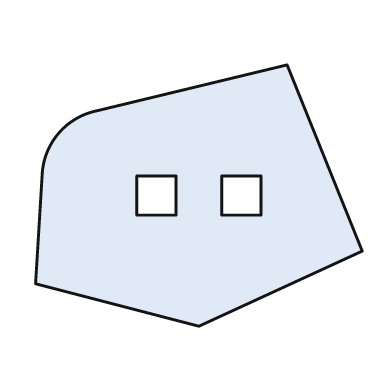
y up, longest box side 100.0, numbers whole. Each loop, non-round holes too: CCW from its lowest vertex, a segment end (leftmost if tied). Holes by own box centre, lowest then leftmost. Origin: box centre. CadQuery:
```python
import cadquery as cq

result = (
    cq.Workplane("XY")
    .moveTo(0.0, -40.0)
    .lineTo(50.0, -17.0)
    .lineTo(27.0, 40.0)
    .lineTo(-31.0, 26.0)
    .threePointArc((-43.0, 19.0), (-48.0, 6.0))
    .lineTo(-50.0, -27.0)
    .close()
    .moveTo(-19.0, -6.0)
    .lineTo(-7.0, -6.0)
    .lineTo(-7.0, 6.0)
    .lineTo(-19.0, 6.0)
    .close()
    .moveTo(7.0, -6.0)
    .lineTo(19.0, -6.0)
    .lineTo(19.0, 6.0)
    .lineTo(7.0, 6.0)
    .close()
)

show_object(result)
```